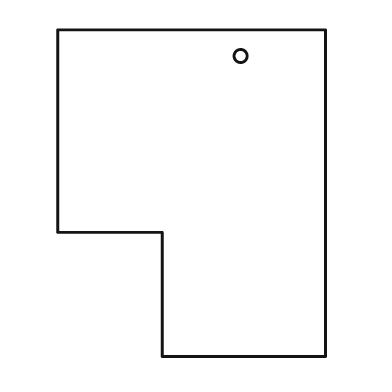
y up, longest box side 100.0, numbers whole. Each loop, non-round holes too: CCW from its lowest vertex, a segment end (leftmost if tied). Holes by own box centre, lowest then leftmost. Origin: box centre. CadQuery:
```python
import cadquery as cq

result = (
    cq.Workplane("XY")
    .moveTo(-9.0, -50.0)
    .lineTo(41.0, -50.0)
    .lineTo(41.0, 50.0)
    .lineTo(-41.0, 50.0)
    .lineTo(-41.0, -12.0)
    .lineTo(-9.0, -12.0)
    .close()
    .moveTo(15.0, 42.0)
    .circle(2.0)
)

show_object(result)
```